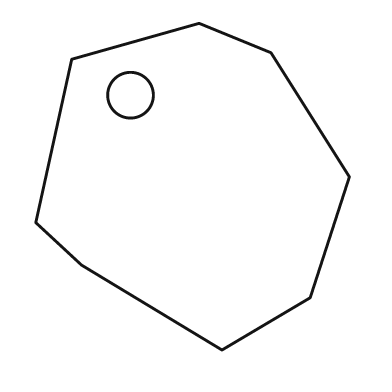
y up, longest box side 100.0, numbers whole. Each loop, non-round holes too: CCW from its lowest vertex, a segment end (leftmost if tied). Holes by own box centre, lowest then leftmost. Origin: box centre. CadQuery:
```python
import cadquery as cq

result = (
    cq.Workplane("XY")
    .moveTo(9.0, -50.0)
    .lineTo(36.0, -34.0)
    .lineTo(48.0, 3.0)
    .lineTo(24.0, 41.0)
    .lineTo(2.0, 50.0)
    .lineTo(-37.0, 39.0)
    .lineTo(-48.0, -11.0)
    .lineTo(-34.0, -24.0)
    .close()
    .moveTo(-19.0, 28.0)
    .circle(7.0)
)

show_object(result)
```